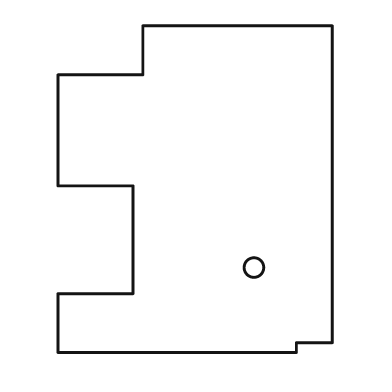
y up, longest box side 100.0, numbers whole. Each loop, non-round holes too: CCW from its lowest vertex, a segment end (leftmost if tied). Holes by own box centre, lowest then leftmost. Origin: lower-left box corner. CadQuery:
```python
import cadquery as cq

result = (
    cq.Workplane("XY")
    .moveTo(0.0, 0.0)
    .lineTo(73.0, 0.0)
    .lineTo(73.0, 3.0)
    .lineTo(84.0, 3.0)
    .lineTo(84.0, 100.0)
    .lineTo(26.0, 100.0)
    .lineTo(26.0, 85.0)
    .lineTo(0.0, 85.0)
    .lineTo(0.0, 51.0)
    .lineTo(23.0, 51.0)
    .lineTo(23.0, 18.0)
    .lineTo(0.0, 18.0)
    .close()
    .moveTo(60.0, 26.0)
    .circle(3.0)
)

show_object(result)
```